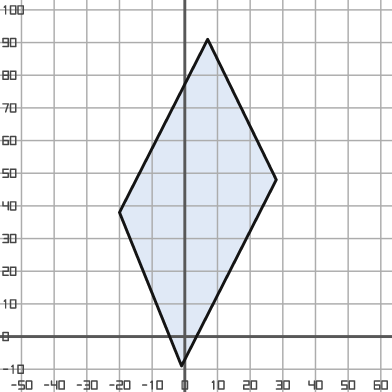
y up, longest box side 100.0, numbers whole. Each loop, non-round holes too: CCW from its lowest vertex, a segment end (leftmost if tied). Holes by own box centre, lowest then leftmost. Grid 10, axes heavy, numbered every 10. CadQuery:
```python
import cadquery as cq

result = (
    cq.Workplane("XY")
    .moveTo(-1.0, -9.0)
    .lineTo(28.0, 48.0)
    .lineTo(7.0, 91.0)
    .lineTo(-20.0, 38.0)
    .close()
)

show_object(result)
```